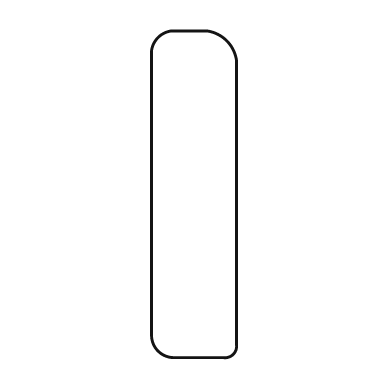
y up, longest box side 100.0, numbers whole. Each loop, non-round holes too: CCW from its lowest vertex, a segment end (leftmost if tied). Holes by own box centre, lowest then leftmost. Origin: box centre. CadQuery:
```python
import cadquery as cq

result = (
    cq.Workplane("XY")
    .moveTo(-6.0, -50.0)
    .lineTo(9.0, -50.0)
    .threePointArc((12.0, -49.0), (13.0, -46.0))
    .lineTo(13.0, 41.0)
    .threePointArc((10.0, 47.0), (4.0, 50.0))
    .lineTo(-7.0, 50.0)
    .threePointArc((-11.0, 48.0), (-13.0, 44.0))
    .lineTo(-13.0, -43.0)
    .threePointArc((-11.0, -48.0), (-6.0, -50.0))
    .close()
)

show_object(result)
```